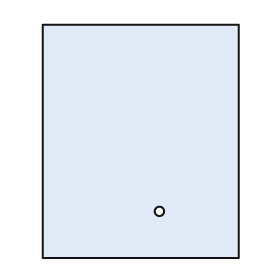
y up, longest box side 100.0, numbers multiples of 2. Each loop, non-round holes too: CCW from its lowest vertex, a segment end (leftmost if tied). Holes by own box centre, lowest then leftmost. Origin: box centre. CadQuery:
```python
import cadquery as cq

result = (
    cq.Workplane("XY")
    .moveTo(-42.0, -50.0)
    .lineTo(42.0, -50.0)
    .lineTo(42.0, 50.0)
    .lineTo(-42.0, 50.0)
    .close()
    .moveTo(8.0, -30.0)
    .circle(2.0)
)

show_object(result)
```